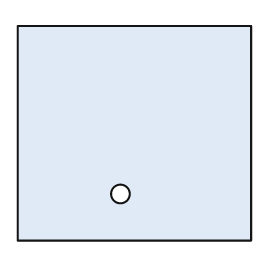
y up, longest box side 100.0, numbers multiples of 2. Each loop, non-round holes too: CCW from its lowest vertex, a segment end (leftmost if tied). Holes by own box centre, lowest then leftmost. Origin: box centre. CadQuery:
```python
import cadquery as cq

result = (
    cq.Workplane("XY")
    .moveTo(-50.0, -46.0)
    .lineTo(50.0, -46.0)
    .lineTo(50.0, 46.0)
    .lineTo(-50.0, 46.0)
    .close()
    .moveTo(-6.0, -26.0)
    .circle(4.0)
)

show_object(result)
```